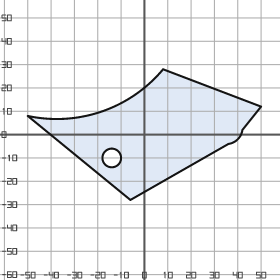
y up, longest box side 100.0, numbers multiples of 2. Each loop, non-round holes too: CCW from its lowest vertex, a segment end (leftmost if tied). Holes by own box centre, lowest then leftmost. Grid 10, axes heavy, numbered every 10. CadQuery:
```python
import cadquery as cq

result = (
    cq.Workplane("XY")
    .moveTo(-6.0, -28.0)
    .lineTo(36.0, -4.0)
    .threePointArc((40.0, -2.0), (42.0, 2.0))
    .lineTo(50.0, 12.0)
    .lineTo(8.0, 28.0)
    .threePointArc((-18.0, 10.0), (-50.0, 8.0))
    .close()
    .moveTo(-14.0, -10.0)
    .circle(4.0)
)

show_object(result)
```